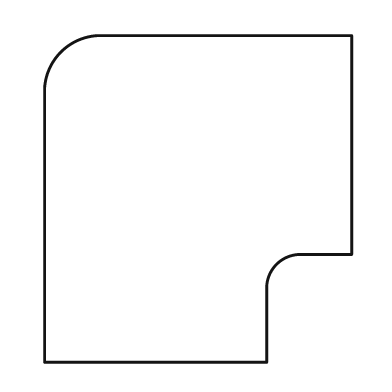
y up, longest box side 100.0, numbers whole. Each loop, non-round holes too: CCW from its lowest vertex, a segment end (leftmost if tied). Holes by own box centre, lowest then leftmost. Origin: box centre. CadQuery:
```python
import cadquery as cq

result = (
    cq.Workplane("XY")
    .moveTo(-47.0, -50.0)
    .lineTo(21.0, -50.0)
    .lineTo(21.0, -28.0)
    .threePointArc((24.0, -20.0), (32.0, -17.0))
    .lineTo(47.0, -17.0)
    .lineTo(47.0, 50.0)
    .lineTo(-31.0, 50.0)
    .threePointArc((-42.0, 45.0), (-47.0, 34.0))
    .close()
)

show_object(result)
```